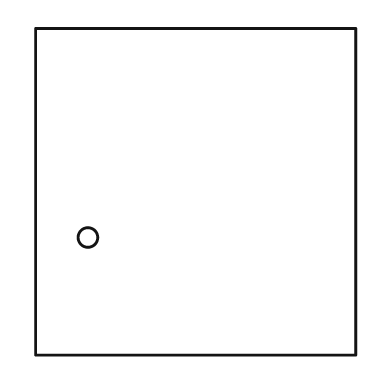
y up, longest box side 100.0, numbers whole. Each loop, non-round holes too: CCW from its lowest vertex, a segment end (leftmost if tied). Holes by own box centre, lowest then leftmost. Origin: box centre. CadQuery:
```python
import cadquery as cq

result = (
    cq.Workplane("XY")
    .moveTo(-49.0, -50.0)
    .lineTo(49.0, -50.0)
    .lineTo(49.0, 50.0)
    .lineTo(-49.0, 50.0)
    .close()
    .moveTo(-33.0, -14.0)
    .circle(3.0)
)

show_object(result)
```